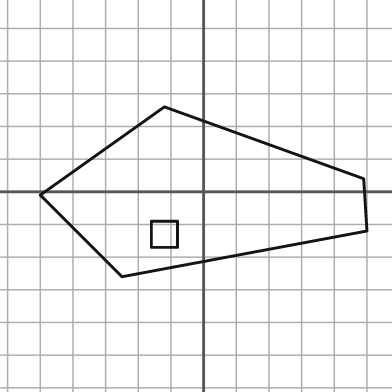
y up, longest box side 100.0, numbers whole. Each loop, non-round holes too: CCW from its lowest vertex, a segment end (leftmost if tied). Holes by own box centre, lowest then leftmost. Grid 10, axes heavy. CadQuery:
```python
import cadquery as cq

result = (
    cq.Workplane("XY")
    .moveTo(-25.0, -26.0)
    .lineTo(50.0, -12.0)
    .lineTo(49.0, 4.0)
    .lineTo(-12.0, 26.0)
    .lineTo(-50.0, -1.0)
    .close()
    .moveTo(-16.0, -17.0)
    .lineTo(-8.0, -17.0)
    .lineTo(-8.0, -9.0)
    .lineTo(-16.0, -9.0)
    .close()
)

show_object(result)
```